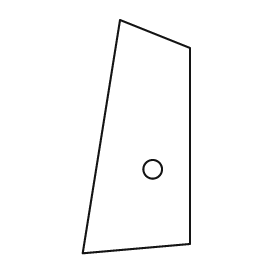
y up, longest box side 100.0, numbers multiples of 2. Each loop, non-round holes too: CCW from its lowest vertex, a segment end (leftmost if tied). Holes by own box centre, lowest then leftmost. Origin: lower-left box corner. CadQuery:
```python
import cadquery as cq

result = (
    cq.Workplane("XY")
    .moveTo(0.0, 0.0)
    .lineTo(46.0, 4.0)
    .lineTo(46.0, 88.0)
    .lineTo(16.0, 100.0)
    .close()
    .moveTo(30.0, 36.0)
    .circle(4.0)
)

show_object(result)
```